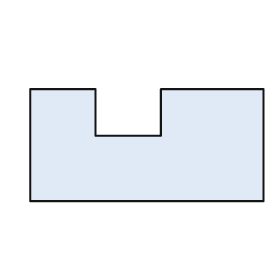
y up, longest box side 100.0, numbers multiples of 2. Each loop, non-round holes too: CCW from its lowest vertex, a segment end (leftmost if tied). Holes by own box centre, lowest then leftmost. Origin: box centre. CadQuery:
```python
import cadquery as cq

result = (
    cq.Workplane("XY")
    .moveTo(-50.0, -24.0)
    .lineTo(50.0, -24.0)
    .lineTo(50.0, 24.0)
    .lineTo(6.0, 24.0)
    .lineTo(6.0, 4.0)
    .lineTo(-22.0, 4.0)
    .lineTo(-22.0, 24.0)
    .lineTo(-50.0, 24.0)
    .close()
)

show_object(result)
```